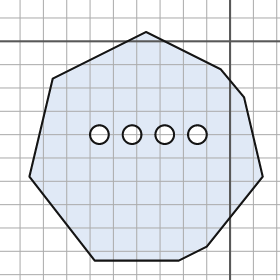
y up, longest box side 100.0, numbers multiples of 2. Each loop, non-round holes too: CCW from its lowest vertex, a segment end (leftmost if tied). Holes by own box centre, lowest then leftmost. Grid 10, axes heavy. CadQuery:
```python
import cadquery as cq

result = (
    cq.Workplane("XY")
    .moveTo(-58.0, -94.0)
    .lineTo(-22.0, -94.0)
    .lineTo(-10.0, -88.0)
    .lineTo(14.0, -58.0)
    .lineTo(6.0, -24.0)
    .lineTo(-4.0, -12.0)
    .lineTo(-36.0, 4.0)
    .lineTo(-76.0, -16.0)
    .lineTo(-86.0, -58.0)
    .close()
    .moveTo(-56.0, -40.0)
    .circle(4.0)
    .moveTo(-42.0, -40.0)
    .circle(4.0)
    .moveTo(-28.0, -40.0)
    .circle(4.0)
    .moveTo(-14.0, -40.0)
    .circle(4.0)
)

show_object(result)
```